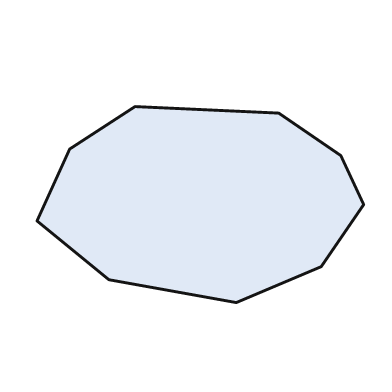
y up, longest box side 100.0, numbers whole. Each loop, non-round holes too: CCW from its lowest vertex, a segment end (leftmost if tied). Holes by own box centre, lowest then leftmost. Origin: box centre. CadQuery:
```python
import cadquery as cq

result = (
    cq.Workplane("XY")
    .moveTo(11.0, -30.0)
    .lineTo(37.0, -19.0)
    .lineTo(50.0, 0.0)
    .lineTo(43.0, 15.0)
    .lineTo(24.0, 28.0)
    .lineTo(-20.0, 30.0)
    .lineTo(-40.0, 17.0)
    .lineTo(-50.0, -5.0)
    .lineTo(-28.0, -23.0)
    .close()
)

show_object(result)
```